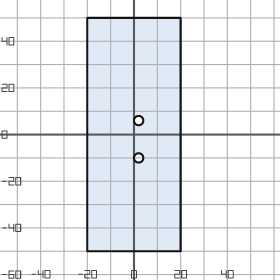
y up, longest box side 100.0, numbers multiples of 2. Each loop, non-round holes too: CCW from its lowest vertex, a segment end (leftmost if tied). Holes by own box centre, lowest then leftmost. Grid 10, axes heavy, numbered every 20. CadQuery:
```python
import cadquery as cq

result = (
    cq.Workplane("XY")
    .moveTo(-20.0, -50.0)
    .lineTo(20.0, -50.0)
    .lineTo(20.0, 50.0)
    .lineTo(-20.0, 50.0)
    .close()
    .moveTo(2.0, -10.0)
    .circle(2.0)
    .moveTo(2.0, 6.0)
    .circle(2.0)
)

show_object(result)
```